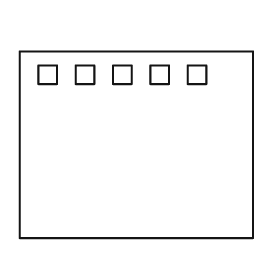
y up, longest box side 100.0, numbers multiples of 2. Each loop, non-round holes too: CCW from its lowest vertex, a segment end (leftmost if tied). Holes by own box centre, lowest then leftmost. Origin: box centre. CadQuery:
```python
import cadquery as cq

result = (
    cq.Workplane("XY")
    .moveTo(-50.0, -40.0)
    .lineTo(50.0, -40.0)
    .lineTo(50.0, 40.0)
    .lineTo(-50.0, 40.0)
    .close()
    .moveTo(-42.0, 26.0)
    .lineTo(-34.0, 26.0)
    .lineTo(-34.0, 34.0)
    .lineTo(-42.0, 34.0)
    .close()
    .moveTo(-26.0, 26.0)
    .lineTo(-18.0, 26.0)
    .lineTo(-18.0, 34.0)
    .lineTo(-26.0, 34.0)
    .close()
    .moveTo(-10.0, 26.0)
    .lineTo(-2.0, 26.0)
    .lineTo(-2.0, 34.0)
    .lineTo(-10.0, 34.0)
    .close()
    .moveTo(6.0, 26.0)
    .lineTo(14.0, 26.0)
    .lineTo(14.0, 34.0)
    .lineTo(6.0, 34.0)
    .close()
    .moveTo(22.0, 26.0)
    .lineTo(30.0, 26.0)
    .lineTo(30.0, 34.0)
    .lineTo(22.0, 34.0)
    .close()
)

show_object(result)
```